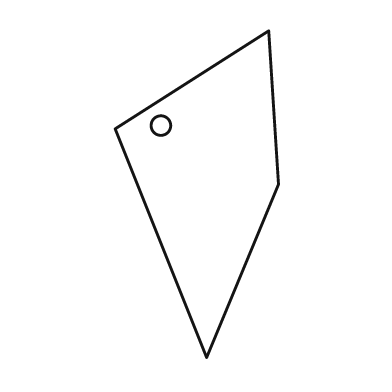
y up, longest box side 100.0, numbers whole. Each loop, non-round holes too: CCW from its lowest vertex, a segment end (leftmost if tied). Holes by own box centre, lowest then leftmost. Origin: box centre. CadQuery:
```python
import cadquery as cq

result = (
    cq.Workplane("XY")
    .moveTo(3.0, -50.0)
    .lineTo(25.0, 3.0)
    .lineTo(22.0, 50.0)
    .lineTo(-25.0, 20.0)
    .close()
    .moveTo(-11.0, 21.0)
    .circle(3.0)
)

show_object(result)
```